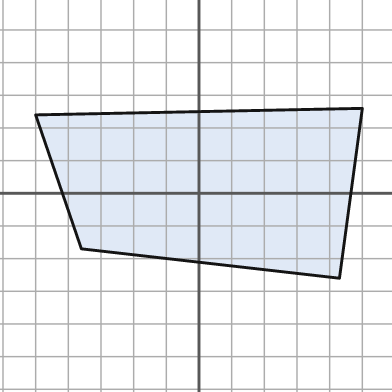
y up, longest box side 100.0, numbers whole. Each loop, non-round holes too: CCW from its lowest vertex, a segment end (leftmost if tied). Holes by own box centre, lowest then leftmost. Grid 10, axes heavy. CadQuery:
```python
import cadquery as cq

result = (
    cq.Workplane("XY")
    .moveTo(43.0, -26.0)
    .lineTo(50.0, 26.0)
    .lineTo(-50.0, 24.0)
    .lineTo(-36.0, -17.0)
    .close()
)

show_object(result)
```